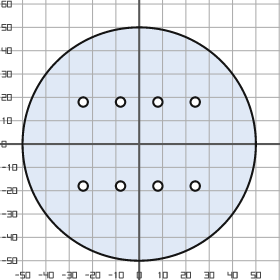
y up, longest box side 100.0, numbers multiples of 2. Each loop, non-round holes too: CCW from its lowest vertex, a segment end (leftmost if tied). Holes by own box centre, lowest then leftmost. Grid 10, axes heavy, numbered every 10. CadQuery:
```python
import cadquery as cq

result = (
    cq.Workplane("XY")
    .moveTo(0.0, 0.0)
    .circle(50.0)
    .moveTo(-24.0, -18.0)
    .circle(2.0)
    .moveTo(-8.0, -18.0)
    .circle(2.0)
    .moveTo(8.0, -18.0)
    .circle(2.0)
    .moveTo(24.0, -18.0)
    .circle(2.0)
    .moveTo(-24.0, 18.0)
    .circle(2.0)
    .moveTo(-8.0, 18.0)
    .circle(2.0)
    .moveTo(8.0, 18.0)
    .circle(2.0)
    .moveTo(24.0, 18.0)
    .circle(2.0)
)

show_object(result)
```